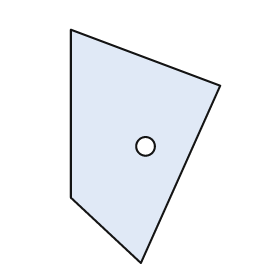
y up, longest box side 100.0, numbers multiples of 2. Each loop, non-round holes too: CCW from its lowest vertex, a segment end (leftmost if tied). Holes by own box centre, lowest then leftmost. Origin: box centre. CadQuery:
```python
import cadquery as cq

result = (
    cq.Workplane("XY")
    .moveTo(-2.0, -50.0)
    .lineTo(32.0, 26.0)
    .lineTo(-32.0, 50.0)
    .lineTo(-32.0, -22.0)
    .close()
    .moveTo(0.0, 0.0)
    .circle(4.0)
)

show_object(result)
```